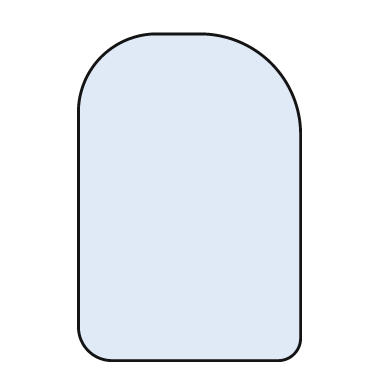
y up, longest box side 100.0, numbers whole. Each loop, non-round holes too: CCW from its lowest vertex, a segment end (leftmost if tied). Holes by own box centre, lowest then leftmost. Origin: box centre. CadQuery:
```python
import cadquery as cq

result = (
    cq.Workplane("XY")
    .moveTo(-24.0, -50.0)
    .lineTo(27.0, -50.0)
    .threePointArc((32.0, -48.0), (34.0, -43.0))
    .lineTo(34.0, 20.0)
    .threePointArc((25.0, 41.0), (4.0, 50.0))
    .lineTo(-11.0, 50.0)
    .threePointArc((-27.0, 43.0), (-34.0, 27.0))
    .lineTo(-34.0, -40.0)
    .threePointArc((-31.0, -47.0), (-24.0, -50.0))
    .close()
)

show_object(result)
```